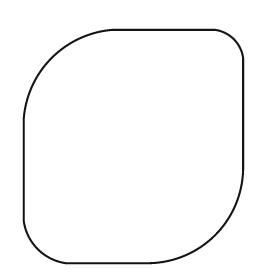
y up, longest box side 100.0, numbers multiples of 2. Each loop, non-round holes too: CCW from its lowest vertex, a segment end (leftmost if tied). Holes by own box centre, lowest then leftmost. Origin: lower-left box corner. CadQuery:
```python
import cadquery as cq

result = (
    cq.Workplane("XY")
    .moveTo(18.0, 0.0)
    .lineTo(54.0, 0.0)
    .threePointArc((82.0, 12.0), (94.0, 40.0))
    .lineTo(94.0, 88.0)
    .threePointArc((90.0, 96.0), (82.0, 100.0))
    .lineTo(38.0, 100.0)
    .threePointArc((12.0, 88.0), (0.0, 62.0))
    .lineTo(0.0, 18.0)
    .threePointArc((6.0, 6.0), (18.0, 0.0))
    .close()
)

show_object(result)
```